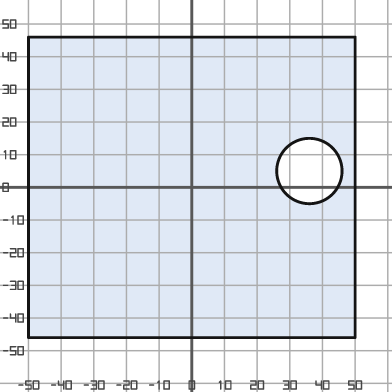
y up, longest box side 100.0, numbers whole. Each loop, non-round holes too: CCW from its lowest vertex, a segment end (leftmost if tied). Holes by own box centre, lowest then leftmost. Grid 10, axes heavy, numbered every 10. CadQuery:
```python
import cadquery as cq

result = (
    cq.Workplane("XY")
    .moveTo(-50.0, -46.0)
    .lineTo(50.0, -46.0)
    .lineTo(50.0, 46.0)
    .lineTo(-50.0, 46.0)
    .close()
    .moveTo(36.0, 5.0)
    .circle(10.0)
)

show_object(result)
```